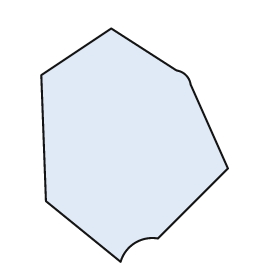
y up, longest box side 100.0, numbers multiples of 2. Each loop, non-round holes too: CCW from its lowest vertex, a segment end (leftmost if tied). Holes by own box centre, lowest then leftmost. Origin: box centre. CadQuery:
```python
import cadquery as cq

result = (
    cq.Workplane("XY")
    .moveTo(-6.0, -50.0)
    .threePointArc((0.0, -42.0), (10.0, -40.0))
    .lineTo(40.0, -10.0)
    .lineTo(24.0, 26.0)
    .threePointArc((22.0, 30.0), (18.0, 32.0))
    .lineTo(-10.0, 50.0)
    .lineTo(-40.0, 30.0)
    .lineTo(-38.0, -24.0)
    .close()
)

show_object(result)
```